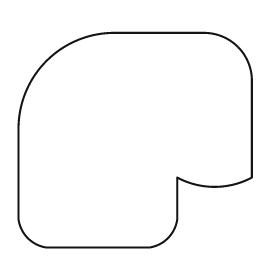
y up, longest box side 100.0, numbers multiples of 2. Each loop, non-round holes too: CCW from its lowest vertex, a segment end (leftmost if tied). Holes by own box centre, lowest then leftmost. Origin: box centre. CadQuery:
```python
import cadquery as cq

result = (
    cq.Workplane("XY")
    .moveTo(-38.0, -46.0)
    .lineTo(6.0, -46.0)
    .threePointArc((14.0, -42.0), (18.0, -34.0))
    .lineTo(18.0, -16.0)
    .threePointArc((34.0, -20.0), (50.0, -16.0))
    .lineTo(50.0, 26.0)
    .threePointArc((44.0, 40.0), (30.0, 46.0))
    .lineTo(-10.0, 46.0)
    .threePointArc((-38.0, 34.0), (-50.0, 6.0))
    .lineTo(-50.0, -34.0)
    .threePointArc((-46.0, -42.0), (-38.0, -46.0))
    .close()
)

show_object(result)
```